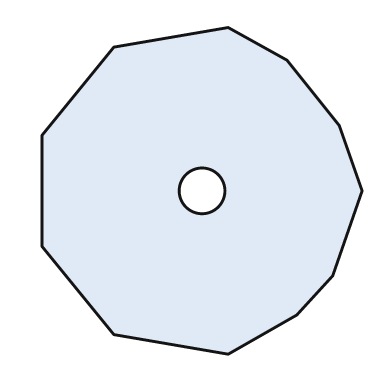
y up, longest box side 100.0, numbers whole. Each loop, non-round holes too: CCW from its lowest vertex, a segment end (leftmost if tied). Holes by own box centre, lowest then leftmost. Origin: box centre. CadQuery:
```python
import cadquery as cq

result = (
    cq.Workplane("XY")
    .moveTo(8.0, -50.0)
    .lineTo(29.0, -38.0)
    .lineTo(40.0, -26.0)
    .lineTo(49.0, 0.0)
    .lineTo(42.0, 20.0)
    .lineTo(26.0, 40.0)
    .lineTo(8.0, 50.0)
    .lineTo(-27.0, 44.0)
    .lineTo(-49.0, 17.0)
    .lineTo(-49.0, -17.0)
    .lineTo(-27.0, -44.0)
    .close()
    .moveTo(0.0, 0.0)
    .circle(7.0)
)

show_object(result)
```